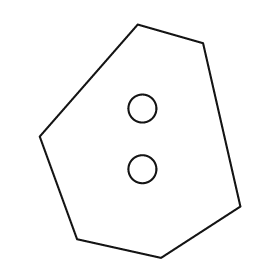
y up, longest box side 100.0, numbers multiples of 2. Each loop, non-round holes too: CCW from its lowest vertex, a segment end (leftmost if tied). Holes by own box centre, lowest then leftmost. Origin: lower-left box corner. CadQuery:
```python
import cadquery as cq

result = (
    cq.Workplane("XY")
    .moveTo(52.0, 0.0)
    .lineTo(86.0, 22.0)
    .lineTo(70.0, 92.0)
    .lineTo(42.0, 100.0)
    .lineTo(0.0, 52.0)
    .lineTo(16.0, 8.0)
    .close()
    .moveTo(44.0, 38.0)
    .circle(6.0)
    .moveTo(44.0, 64.0)
    .circle(6.0)
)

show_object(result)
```